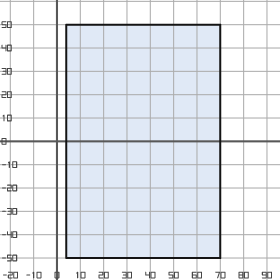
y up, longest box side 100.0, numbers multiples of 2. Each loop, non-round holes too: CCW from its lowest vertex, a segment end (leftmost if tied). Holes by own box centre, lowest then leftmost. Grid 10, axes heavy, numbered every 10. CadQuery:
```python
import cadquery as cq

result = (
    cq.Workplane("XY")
    .moveTo(4.0, -50.0)
    .lineTo(70.0, -50.0)
    .lineTo(70.0, 50.0)
    .lineTo(4.0, 50.0)
    .close()
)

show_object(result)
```